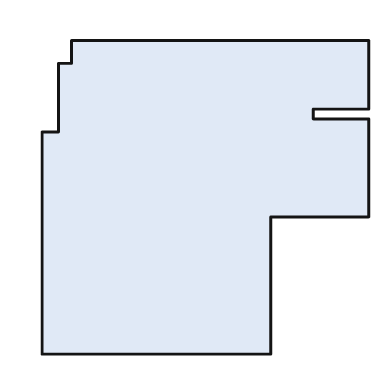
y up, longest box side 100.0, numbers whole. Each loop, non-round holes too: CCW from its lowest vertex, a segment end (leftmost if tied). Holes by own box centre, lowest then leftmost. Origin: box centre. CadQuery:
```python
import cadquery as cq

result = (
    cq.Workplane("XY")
    .moveTo(-50.0, -48.0)
    .lineTo(20.0, -48.0)
    .lineTo(20.0, -6.0)
    .lineTo(50.0, -6.0)
    .lineTo(50.0, 24.0)
    .lineTo(33.0, 24.0)
    .lineTo(33.0, 27.0)
    .lineTo(50.0, 27.0)
    .lineTo(50.0, 48.0)
    .lineTo(-41.0, 48.0)
    .lineTo(-41.0, 41.0)
    .lineTo(-45.0, 41.0)
    .lineTo(-45.0, 20.0)
    .lineTo(-50.0, 20.0)
    .close()
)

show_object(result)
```